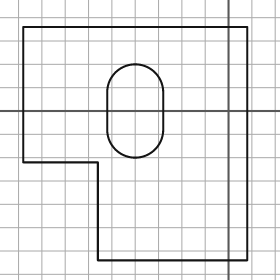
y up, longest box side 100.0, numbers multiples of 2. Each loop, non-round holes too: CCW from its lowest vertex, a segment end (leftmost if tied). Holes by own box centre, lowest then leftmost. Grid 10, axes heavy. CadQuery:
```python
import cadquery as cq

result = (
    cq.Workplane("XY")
    .moveTo(-56.0, -64.0)
    .lineTo(8.0, -64.0)
    .lineTo(8.0, 36.0)
    .lineTo(-88.0, 36.0)
    .lineTo(-88.0, -22.0)
    .lineTo(-56.0, -22.0)
    .close()
    .moveTo(-52.0, -8.0)
    .threePointArc((-40.0, -20.0), (-28.0, -8.0))
    .lineTo(-28.0, 8.0)
    .threePointArc((-40.0, 20.0), (-52.0, 8.0))
    .close()
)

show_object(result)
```